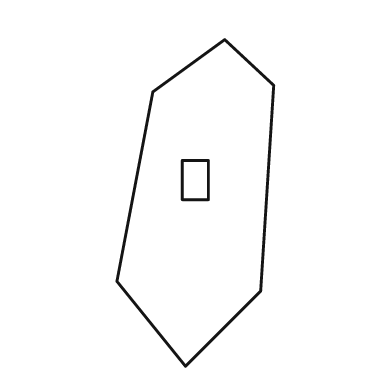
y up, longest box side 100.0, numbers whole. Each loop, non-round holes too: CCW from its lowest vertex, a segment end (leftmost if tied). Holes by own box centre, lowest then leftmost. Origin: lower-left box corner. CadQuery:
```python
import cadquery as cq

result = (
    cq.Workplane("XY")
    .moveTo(21.0, 0.0)
    .lineTo(44.0, 23.0)
    .lineTo(48.0, 86.0)
    .lineTo(33.0, 100.0)
    .lineTo(11.0, 84.0)
    .lineTo(0.0, 26.0)
    .close()
    .moveTo(20.0, 51.0)
    .lineTo(28.0, 51.0)
    .lineTo(28.0, 63.0)
    .lineTo(20.0, 63.0)
    .close()
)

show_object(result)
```